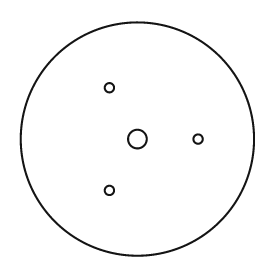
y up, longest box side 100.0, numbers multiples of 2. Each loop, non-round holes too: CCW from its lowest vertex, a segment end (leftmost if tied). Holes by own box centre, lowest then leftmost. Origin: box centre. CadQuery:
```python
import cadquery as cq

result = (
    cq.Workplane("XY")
    .moveTo(0.0, 0.0)
    .circle(50.0)
    .moveTo(-12.0, -22.0)
    .circle(2.0)
    .moveTo(0.0, 0.0)
    .circle(4.0)
    .moveTo(26.0, 0.0)
    .circle(2.0)
    .moveTo(-12.0, 22.0)
    .circle(2.0)
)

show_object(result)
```